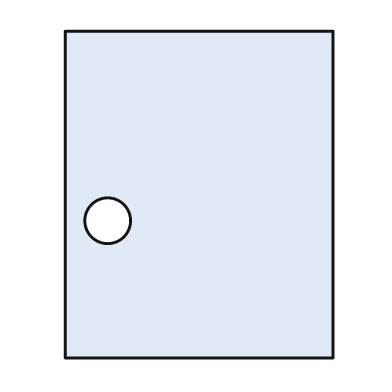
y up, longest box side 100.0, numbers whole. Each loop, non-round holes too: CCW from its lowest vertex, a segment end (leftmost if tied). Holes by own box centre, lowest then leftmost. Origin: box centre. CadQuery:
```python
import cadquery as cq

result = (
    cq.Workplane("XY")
    .moveTo(-41.0, -50.0)
    .lineTo(41.0, -50.0)
    .lineTo(41.0, 50.0)
    .lineTo(-41.0, 50.0)
    .close()
    .moveTo(-28.0, -8.0)
    .circle(7.0)
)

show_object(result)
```